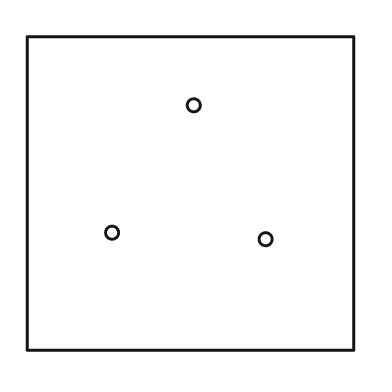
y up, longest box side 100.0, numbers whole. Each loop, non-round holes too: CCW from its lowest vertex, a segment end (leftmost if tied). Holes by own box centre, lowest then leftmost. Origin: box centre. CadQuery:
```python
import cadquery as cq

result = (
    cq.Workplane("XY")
    .moveTo(-50.0, -48.0)
    .lineTo(50.0, -48.0)
    .lineTo(50.0, 48.0)
    .lineTo(-50.0, 48.0)
    .close()
    .moveTo(23.0, -14.0)
    .circle(2.0)
    .moveTo(-24.0, -12.0)
    .circle(2.0)
    .moveTo(1.0, 27.0)
    .circle(2.0)
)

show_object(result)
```